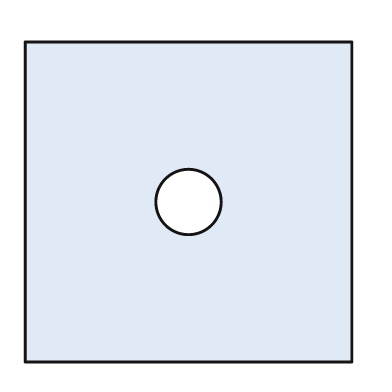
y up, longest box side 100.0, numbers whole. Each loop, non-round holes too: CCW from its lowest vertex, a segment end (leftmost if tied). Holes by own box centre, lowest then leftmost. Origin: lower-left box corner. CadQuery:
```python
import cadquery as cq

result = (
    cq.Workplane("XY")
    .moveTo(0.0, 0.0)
    .lineTo(100.0, 0.0)
    .lineTo(100.0, 98.0)
    .lineTo(0.0, 98.0)
    .close()
    .moveTo(50.0, 49.0)
    .circle(10.0)
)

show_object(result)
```